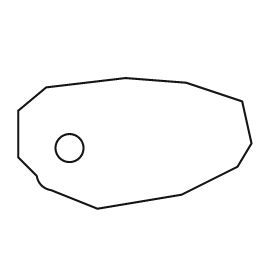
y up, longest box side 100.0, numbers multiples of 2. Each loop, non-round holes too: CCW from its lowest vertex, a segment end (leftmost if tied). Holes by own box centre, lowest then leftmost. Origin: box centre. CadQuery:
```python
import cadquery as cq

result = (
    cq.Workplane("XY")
    .moveTo(-16.0, -28.0)
    .lineTo(20.0, -22.0)
    .lineTo(44.0, -10.0)
    .lineTo(50.0, 0.0)
    .lineTo(46.0, 18.0)
    .lineTo(22.0, 26.0)
    .lineTo(-4.0, 28.0)
    .lineTo(-38.0, 24.0)
    .lineTo(-50.0, 14.0)
    .lineTo(-50.0, -6.0)
    .lineTo(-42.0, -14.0)
    .threePointArc((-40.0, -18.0), (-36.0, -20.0))
    .close()
    .moveTo(-28.0, -2.0)
    .circle(6.0)
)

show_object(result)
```